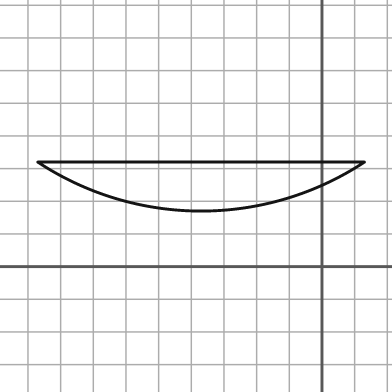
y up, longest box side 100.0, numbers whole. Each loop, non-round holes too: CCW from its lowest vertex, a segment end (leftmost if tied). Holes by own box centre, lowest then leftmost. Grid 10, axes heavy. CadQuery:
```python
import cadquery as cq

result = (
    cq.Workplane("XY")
    .moveTo(-87.0, 32.0)
    .threePointArc((-37.0, 17.0), (13.0, 32.0))
    .close()
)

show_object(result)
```